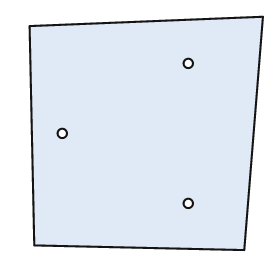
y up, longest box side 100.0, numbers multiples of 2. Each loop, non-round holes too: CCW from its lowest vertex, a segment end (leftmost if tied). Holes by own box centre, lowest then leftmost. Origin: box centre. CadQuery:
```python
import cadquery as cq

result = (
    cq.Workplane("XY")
    .moveTo(42.0, -50.0)
    .lineTo(50.0, 50.0)
    .lineTo(-50.0, 46.0)
    .lineTo(-48.0, -48.0)
    .close()
    .moveTo(18.0, -30.0)
    .circle(2.0)
    .moveTo(-36.0, 0.0)
    .circle(2.0)
    .moveTo(18.0, 30.0)
    .circle(2.0)
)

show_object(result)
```